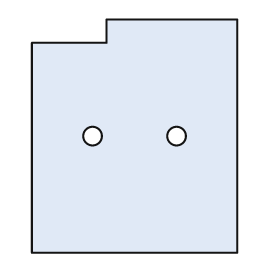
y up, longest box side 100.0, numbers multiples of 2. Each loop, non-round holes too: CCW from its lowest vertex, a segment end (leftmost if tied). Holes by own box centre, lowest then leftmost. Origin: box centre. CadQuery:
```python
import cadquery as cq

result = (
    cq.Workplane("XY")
    .moveTo(-44.0, -50.0)
    .lineTo(44.0, -50.0)
    .lineTo(44.0, 50.0)
    .lineTo(-12.0, 50.0)
    .lineTo(-12.0, 40.0)
    .lineTo(-44.0, 40.0)
    .close()
    .moveTo(-18.0, 0.0)
    .circle(4.0)
    .moveTo(18.0, 0.0)
    .circle(4.0)
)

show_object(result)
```